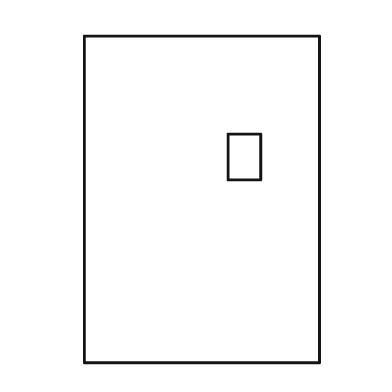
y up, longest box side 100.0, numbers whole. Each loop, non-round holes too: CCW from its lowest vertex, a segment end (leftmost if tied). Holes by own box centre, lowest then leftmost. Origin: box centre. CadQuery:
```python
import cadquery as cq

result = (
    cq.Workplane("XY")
    .moveTo(-36.0, -50.0)
    .lineTo(36.0, -50.0)
    .lineTo(36.0, 50.0)
    .lineTo(-36.0, 50.0)
    .close()
    .moveTo(8.0, 6.0)
    .lineTo(18.0, 6.0)
    .lineTo(18.0, 20.0)
    .lineTo(8.0, 20.0)
    .close()
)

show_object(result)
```